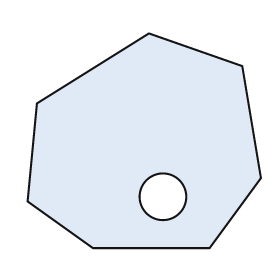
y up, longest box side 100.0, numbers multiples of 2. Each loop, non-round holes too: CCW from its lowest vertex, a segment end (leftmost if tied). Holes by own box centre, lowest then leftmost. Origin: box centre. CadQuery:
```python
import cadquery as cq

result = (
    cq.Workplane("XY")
    .moveTo(-22.0, -46.0)
    .lineTo(28.0, -46.0)
    .lineTo(50.0, -16.0)
    .lineTo(42.0, 32.0)
    .lineTo(2.0, 46.0)
    .lineTo(-46.0, 16.0)
    .lineTo(-50.0, -26.0)
    .close()
    .moveTo(8.0, -24.0)
    .circle(10.0)
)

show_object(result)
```